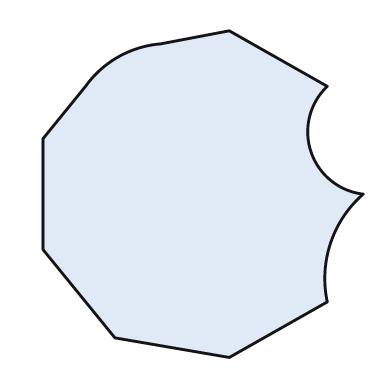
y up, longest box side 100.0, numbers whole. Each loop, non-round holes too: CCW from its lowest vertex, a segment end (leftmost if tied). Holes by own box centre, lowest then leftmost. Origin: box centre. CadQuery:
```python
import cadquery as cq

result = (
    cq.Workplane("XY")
    .moveTo(8.0, -50.0)
    .lineTo(38.0, -33.0)
    .threePointArc((39.0, -15.0), (49.0, 0.0))
    .threePointArc((33.0, 13.0), (38.0, 33.0))
    .lineTo(8.0, 50.0)
    .lineTo(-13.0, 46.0)
    .threePointArc((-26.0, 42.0), (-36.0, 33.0))
    .lineTo(-49.0, 17.0)
    .lineTo(-49.0, -17.0)
    .lineTo(-27.0, -44.0)
    .close()
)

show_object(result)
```